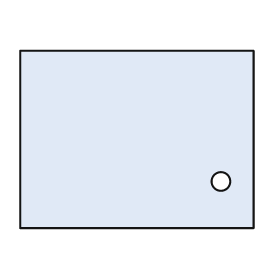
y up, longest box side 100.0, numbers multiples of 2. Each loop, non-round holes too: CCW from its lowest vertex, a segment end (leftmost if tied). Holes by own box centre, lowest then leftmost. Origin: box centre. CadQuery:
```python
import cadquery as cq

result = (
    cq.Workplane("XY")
    .moveTo(-50.0, -38.0)
    .lineTo(50.0, -38.0)
    .lineTo(50.0, 38.0)
    .lineTo(-50.0, 38.0)
    .close()
    .moveTo(36.0, -18.0)
    .circle(4.0)
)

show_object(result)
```